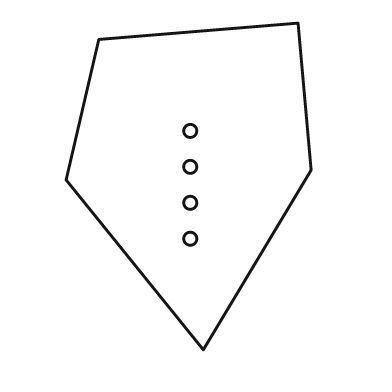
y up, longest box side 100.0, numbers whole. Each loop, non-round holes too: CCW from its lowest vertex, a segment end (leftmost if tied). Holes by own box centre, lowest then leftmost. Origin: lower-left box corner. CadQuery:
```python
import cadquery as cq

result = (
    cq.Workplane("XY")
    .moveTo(42.0, 0.0)
    .lineTo(75.0, 55.0)
    .lineTo(71.0, 100.0)
    .lineTo(10.0, 95.0)
    .lineTo(0.0, 52.0)
    .close()
    .moveTo(38.0, 34.0)
    .circle(2.0)
    .moveTo(38.0, 45.0)
    .circle(2.0)
    .moveTo(38.0, 56.0)
    .circle(2.0)
    .moveTo(38.0, 67.0)
    .circle(2.0)
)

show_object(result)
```